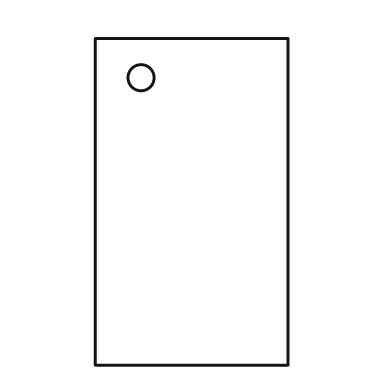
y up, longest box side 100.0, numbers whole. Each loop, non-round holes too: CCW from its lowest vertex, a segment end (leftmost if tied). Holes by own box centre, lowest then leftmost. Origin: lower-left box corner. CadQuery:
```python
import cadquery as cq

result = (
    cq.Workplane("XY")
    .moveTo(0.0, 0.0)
    .lineTo(59.0, 0.0)
    .lineTo(59.0, 100.0)
    .lineTo(0.0, 100.0)
    .close()
    .moveTo(14.0, 88.0)
    .circle(4.0)
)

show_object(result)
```